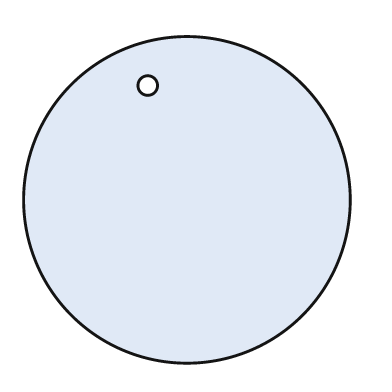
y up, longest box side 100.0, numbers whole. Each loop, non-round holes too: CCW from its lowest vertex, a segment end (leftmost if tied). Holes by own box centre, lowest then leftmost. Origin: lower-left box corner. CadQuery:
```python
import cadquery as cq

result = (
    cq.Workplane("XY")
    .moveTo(50.0, 50.0)
    .circle(50.0)
    .moveTo(38.0, 85.0)
    .circle(3.0)
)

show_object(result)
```